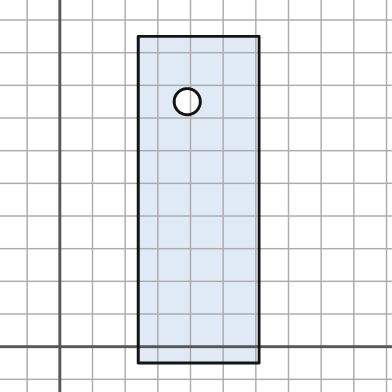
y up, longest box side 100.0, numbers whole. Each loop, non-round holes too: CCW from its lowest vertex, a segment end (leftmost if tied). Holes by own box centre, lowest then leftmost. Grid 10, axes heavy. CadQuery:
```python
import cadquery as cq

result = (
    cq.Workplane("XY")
    .moveTo(24.0, -5.0)
    .lineTo(61.0, -5.0)
    .lineTo(61.0, 95.0)
    .lineTo(24.0, 95.0)
    .close()
    .moveTo(39.0, 75.0)
    .circle(4.0)
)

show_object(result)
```